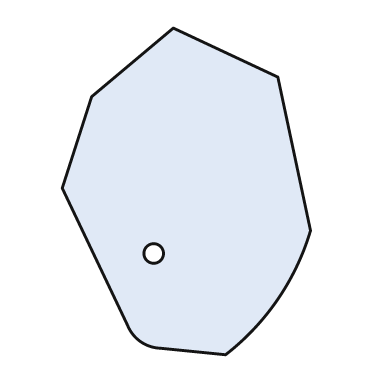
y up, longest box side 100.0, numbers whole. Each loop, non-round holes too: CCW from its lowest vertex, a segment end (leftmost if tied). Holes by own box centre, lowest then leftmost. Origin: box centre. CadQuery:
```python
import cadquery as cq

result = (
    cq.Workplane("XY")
    .moveTo(12.0, -50.0)
    .threePointArc((28.0, -33.0), (38.0, -12.0))
    .lineTo(28.0, 35.0)
    .lineTo(-4.0, 50.0)
    .lineTo(-29.0, 29.0)
    .lineTo(-38.0, 1.0)
    .lineTo(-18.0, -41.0)
    .threePointArc((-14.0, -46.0), (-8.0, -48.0))
    .close()
    .moveTo(-10.0, -19.0)
    .circle(3.0)
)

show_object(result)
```